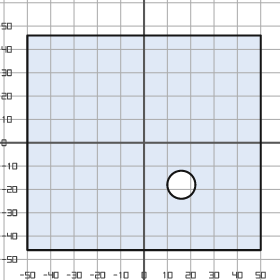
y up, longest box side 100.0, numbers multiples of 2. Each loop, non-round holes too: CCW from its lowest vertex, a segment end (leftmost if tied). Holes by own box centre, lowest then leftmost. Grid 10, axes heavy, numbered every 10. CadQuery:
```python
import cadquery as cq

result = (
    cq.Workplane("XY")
    .moveTo(-50.0, -46.0)
    .lineTo(50.0, -46.0)
    .lineTo(50.0, 46.0)
    .lineTo(-50.0, 46.0)
    .close()
    .moveTo(16.0, -18.0)
    .circle(6.0)
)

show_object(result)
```